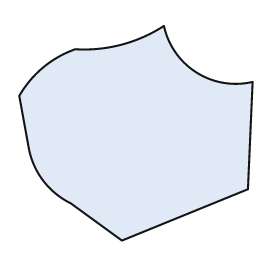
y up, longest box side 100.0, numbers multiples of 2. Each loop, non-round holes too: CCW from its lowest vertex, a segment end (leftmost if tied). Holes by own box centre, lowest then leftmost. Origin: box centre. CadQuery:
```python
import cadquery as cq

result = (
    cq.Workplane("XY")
    .moveTo(-6.0, -46.0)
    .lineTo(48.0, -24.0)
    .lineTo(50.0, 22.0)
    .threePointArc((26.0, 26.0), (12.0, 46.0))
    .threePointArc((-6.0, 38.0), (-26.0, 36.0))
    .threePointArc((-40.0, 28.0), (-50.0, 16.0))
    .lineTo(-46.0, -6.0)
    .threePointArc((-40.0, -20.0), (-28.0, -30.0))
    .close()
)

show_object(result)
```